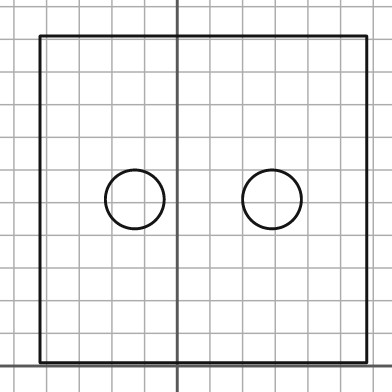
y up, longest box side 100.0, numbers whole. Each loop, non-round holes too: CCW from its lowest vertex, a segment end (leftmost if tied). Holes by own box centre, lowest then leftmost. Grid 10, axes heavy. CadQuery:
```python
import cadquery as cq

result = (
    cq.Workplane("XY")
    .moveTo(-42.0, 1.0)
    .lineTo(58.0, 1.0)
    .lineTo(58.0, 101.0)
    .lineTo(-42.0, 101.0)
    .close()
    .moveTo(-13.0, 51.0)
    .circle(9.0)
    .moveTo(29.0, 51.0)
    .circle(9.0)
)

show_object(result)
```